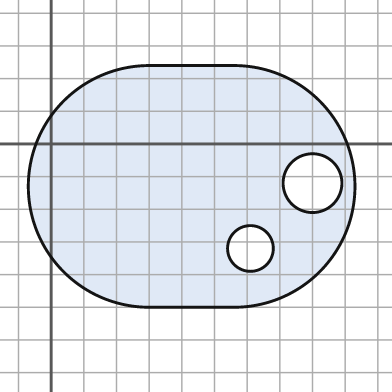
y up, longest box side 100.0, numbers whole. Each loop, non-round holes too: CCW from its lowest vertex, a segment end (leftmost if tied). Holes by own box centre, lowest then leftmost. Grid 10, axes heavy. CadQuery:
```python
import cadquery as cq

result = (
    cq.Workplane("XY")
    .moveTo(30.0, -50.0)
    .lineTo(56.0, -50.0)
    .threePointArc((93.0, -13.0), (56.0, 24.0))
    .lineTo(30.0, 24.0)
    .threePointArc((-7.0, -13.0), (30.0, -50.0))
    .close()
    .moveTo(61.0, -32.0)
    .circle(7.0)
    .moveTo(80.0, -12.0)
    .circle(9.0)
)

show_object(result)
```